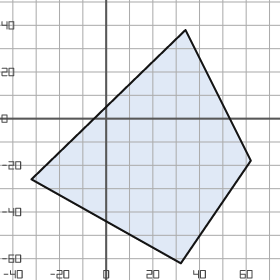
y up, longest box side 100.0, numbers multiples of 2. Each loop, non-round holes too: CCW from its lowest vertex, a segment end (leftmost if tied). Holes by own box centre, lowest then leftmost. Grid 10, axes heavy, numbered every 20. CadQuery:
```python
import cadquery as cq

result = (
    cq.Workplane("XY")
    .moveTo(32.0, -62.0)
    .lineTo(62.0, -18.0)
    .lineTo(34.0, 38.0)
    .lineTo(-32.0, -26.0)
    .close()
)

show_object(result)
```